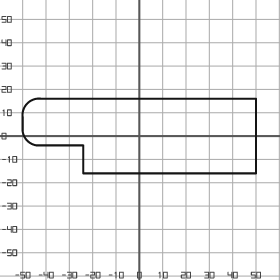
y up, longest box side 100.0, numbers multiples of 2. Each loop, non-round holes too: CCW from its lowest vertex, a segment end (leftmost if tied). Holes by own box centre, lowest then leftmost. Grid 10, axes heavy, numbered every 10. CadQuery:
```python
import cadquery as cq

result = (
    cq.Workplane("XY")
    .moveTo(-24.0, -16.0)
    .lineTo(50.0, -16.0)
    .lineTo(50.0, 16.0)
    .lineTo(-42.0, 16.0)
    .threePointArc((-48.0, 14.0), (-50.0, 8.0))
    .lineTo(-50.0, 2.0)
    .threePointArc((-48.0, -2.0), (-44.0, -4.0))
    .lineTo(-24.0, -4.0)
    .close()
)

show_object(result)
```